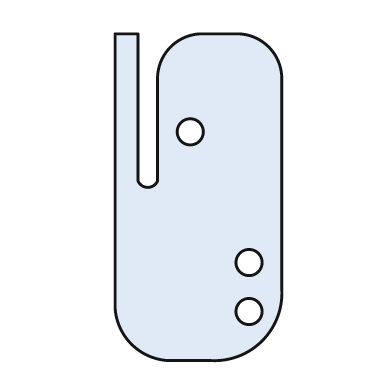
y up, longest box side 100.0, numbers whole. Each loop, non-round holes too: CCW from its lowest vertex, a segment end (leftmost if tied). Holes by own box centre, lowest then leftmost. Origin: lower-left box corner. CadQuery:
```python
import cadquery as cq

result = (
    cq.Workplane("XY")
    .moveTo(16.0, 0.0)
    .lineTo(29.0, 0.0)
    .threePointArc((45.0, 6.0), (51.0, 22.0))
    .lineTo(51.0, 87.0)
    .threePointArc((47.0, 96.0), (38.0, 100.0))
    .lineTo(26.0, 100.0)
    .threePointArc((17.0, 96.0), (13.0, 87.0))
    .lineTo(13.0, 55.0)
    .threePointArc((10.0, 53.0), (7.0, 55.0))
    .lineTo(7.0, 100.0)
    .lineTo(0.0, 100.0)
    .lineTo(0.0, 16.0)
    .threePointArc((5.0, 5.0), (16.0, 0.0))
    .close()
    .moveTo(41.0, 15.0)
    .circle(4.0)
    .moveTo(41.0, 30.0)
    .circle(4.0)
    .moveTo(23.0, 70.0)
    .circle(4.0)
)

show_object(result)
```